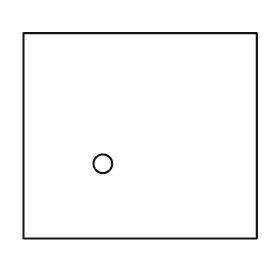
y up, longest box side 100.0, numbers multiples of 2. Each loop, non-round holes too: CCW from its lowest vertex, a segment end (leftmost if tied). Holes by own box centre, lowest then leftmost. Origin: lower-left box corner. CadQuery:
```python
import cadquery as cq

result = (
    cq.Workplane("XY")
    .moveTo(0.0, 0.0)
    .lineTo(100.0, 0.0)
    .lineTo(100.0, 88.0)
    .lineTo(0.0, 88.0)
    .close()
    .moveTo(34.0, 32.0)
    .circle(4.0)
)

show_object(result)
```